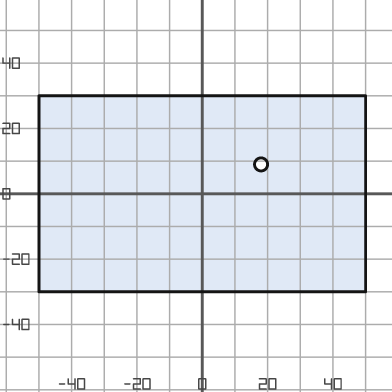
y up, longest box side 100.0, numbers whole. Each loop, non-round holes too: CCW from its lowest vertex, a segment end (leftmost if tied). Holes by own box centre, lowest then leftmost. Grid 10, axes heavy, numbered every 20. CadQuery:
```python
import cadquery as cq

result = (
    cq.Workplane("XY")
    .moveTo(-50.0, -30.0)
    .lineTo(50.0, -30.0)
    .lineTo(50.0, 30.0)
    .lineTo(-50.0, 30.0)
    .close()
    .moveTo(18.0, 9.0)
    .circle(2.0)
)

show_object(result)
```